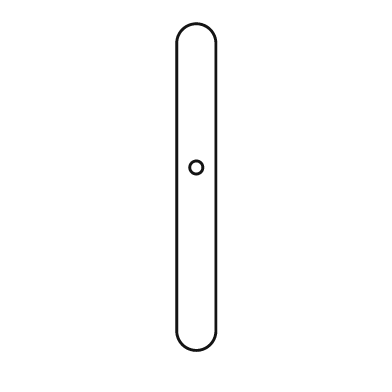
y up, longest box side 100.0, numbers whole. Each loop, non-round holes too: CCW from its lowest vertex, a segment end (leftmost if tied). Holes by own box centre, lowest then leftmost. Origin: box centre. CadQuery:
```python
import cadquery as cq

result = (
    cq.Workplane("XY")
    .moveTo(-6.0, -44.0)
    .threePointArc((0.0, -50.0), (6.0, -44.0))
    .lineTo(6.0, 44.0)
    .threePointArc((0.0, 50.0), (-6.0, 44.0))
    .close()
    .moveTo(0.0, 6.0)
    .circle(2.0)
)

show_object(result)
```